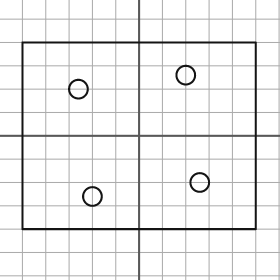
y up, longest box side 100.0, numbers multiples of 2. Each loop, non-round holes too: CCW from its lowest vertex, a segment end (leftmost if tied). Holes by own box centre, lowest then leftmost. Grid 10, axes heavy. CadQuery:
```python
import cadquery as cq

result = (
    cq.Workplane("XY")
    .moveTo(-50.0, -40.0)
    .lineTo(50.0, -40.0)
    .lineTo(50.0, 40.0)
    .lineTo(-50.0, 40.0)
    .close()
    .moveTo(-20.0, -26.0)
    .circle(4.0)
    .moveTo(26.0, -20.0)
    .circle(4.0)
    .moveTo(-26.0, 20.0)
    .circle(4.0)
    .moveTo(20.0, 26.0)
    .circle(4.0)
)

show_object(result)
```